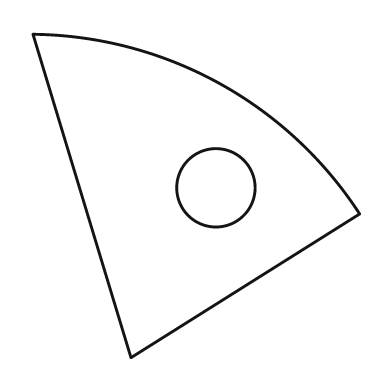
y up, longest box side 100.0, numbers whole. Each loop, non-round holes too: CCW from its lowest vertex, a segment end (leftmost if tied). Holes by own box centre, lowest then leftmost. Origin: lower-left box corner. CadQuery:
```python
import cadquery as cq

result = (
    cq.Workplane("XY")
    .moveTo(30.0, 0.0)
    .lineTo(100.0, 44.0)
    .threePointArc((57.0, 84.0), (0.0, 99.0))
    .close()
    .moveTo(56.0, 52.0)
    .circle(12.0)
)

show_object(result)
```